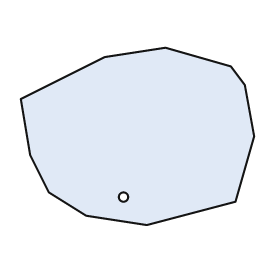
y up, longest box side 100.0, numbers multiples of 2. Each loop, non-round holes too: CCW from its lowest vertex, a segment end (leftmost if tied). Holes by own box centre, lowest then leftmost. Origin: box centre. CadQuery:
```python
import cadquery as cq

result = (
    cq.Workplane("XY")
    .moveTo(4.0, -38.0)
    .lineTo(42.0, -28.0)
    .lineTo(50.0, 0.0)
    .lineTo(46.0, 22.0)
    .lineTo(40.0, 30.0)
    .lineTo(12.0, 38.0)
    .lineTo(-14.0, 34.0)
    .lineTo(-50.0, 16.0)
    .lineTo(-46.0, -8.0)
    .lineTo(-38.0, -24.0)
    .lineTo(-22.0, -34.0)
    .close()
    .moveTo(-6.0, -26.0)
    .circle(2.0)
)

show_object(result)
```